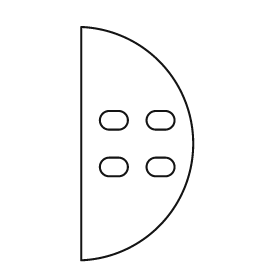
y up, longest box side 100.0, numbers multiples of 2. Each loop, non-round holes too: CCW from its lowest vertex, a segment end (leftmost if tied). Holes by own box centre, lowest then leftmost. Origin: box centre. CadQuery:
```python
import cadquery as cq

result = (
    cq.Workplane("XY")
    .moveTo(-24.0, -50.0)
    .threePointArc((24.0, 0.0), (-24.0, 50.0))
    .close()
    .moveTo(-12.0, -14.0)
    .lineTo(-8.0, -14.0)
    .threePointArc((-4.0, -10.0), (-8.0, -6.0))
    .lineTo(-12.0, -6.0)
    .threePointArc((-16.0, -10.0), (-12.0, -14.0))
    .close()
    .moveTo(8.0, -14.0)
    .lineTo(12.0, -14.0)
    .threePointArc((16.0, -10.0), (12.0, -6.0))
    .lineTo(8.0, -6.0)
    .threePointArc((4.0, -10.0), (8.0, -14.0))
    .close()
    .moveTo(-12.0, 6.0)
    .lineTo(-8.0, 6.0)
    .threePointArc((-4.0, 10.0), (-8.0, 14.0))
    .lineTo(-12.0, 14.0)
    .threePointArc((-16.0, 10.0), (-12.0, 6.0))
    .close()
    .moveTo(8.0, 6.0)
    .lineTo(12.0, 6.0)
    .threePointArc((16.0, 10.0), (12.0, 14.0))
    .lineTo(8.0, 14.0)
    .threePointArc((4.0, 10.0), (8.0, 6.0))
    .close()
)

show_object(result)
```